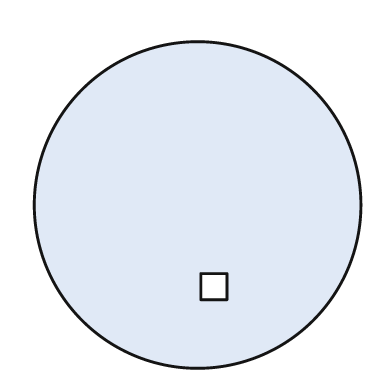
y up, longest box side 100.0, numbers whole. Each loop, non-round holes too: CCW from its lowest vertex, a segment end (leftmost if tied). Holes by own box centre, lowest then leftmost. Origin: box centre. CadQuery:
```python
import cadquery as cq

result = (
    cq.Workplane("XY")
    .moveTo(0.0, 0.0)
    .circle(50.0)
    .moveTo(1.0, -29.0)
    .lineTo(9.0, -29.0)
    .lineTo(9.0, -21.0)
    .lineTo(1.0, -21.0)
    .close()
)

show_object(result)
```